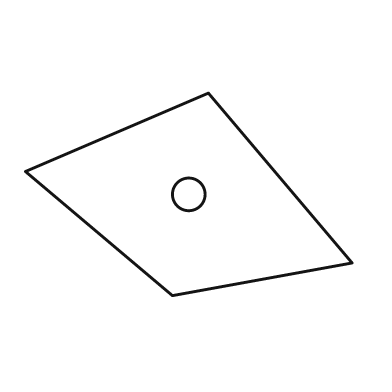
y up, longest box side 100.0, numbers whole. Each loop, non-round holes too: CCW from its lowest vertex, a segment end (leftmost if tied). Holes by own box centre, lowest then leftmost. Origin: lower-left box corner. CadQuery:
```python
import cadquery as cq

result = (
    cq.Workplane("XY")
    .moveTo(45.0, 0.0)
    .lineTo(100.0, 10.0)
    .lineTo(56.0, 62.0)
    .lineTo(0.0, 38.0)
    .close()
    .moveTo(50.0, 31.0)
    .circle(5.0)
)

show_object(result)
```